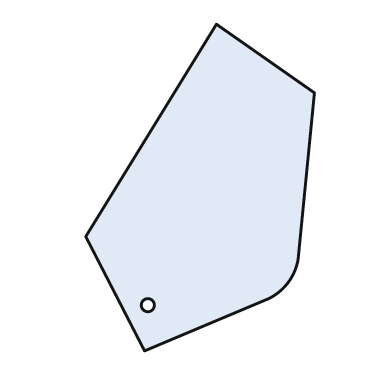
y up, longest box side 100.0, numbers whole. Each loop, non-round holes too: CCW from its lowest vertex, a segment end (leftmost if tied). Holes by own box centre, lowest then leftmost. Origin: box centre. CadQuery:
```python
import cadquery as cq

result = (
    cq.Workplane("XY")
    .moveTo(-17.0, -50.0)
    .lineTo(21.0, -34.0)
    .threePointArc((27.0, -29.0), (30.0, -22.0))
    .lineTo(35.0, 29.0)
    .lineTo(5.0, 50.0)
    .lineTo(-35.0, -15.0)
    .close()
    .moveTo(-16.0, -36.0)
    .circle(2.0)
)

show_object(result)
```